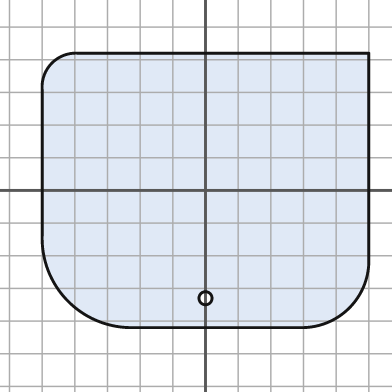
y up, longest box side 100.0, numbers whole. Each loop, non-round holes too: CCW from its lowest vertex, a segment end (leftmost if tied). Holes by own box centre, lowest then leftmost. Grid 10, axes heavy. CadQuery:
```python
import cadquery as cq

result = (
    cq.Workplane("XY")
    .moveTo(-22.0, -42.0)
    .lineTo(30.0, -42.0)
    .threePointArc((44.0, -36.0), (50.0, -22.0))
    .lineTo(50.0, 42.0)
    .lineTo(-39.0, 42.0)
    .threePointArc((-47.0, 39.0), (-50.0, 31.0))
    .lineTo(-50.0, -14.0)
    .threePointArc((-42.0, -34.0), (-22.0, -42.0))
    .close()
    .moveTo(0.0, -33.0)
    .circle(2.0)
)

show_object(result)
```